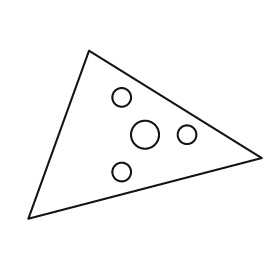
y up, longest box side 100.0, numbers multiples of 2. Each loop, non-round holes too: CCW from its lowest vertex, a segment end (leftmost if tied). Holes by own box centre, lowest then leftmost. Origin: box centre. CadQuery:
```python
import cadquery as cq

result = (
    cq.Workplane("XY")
    .moveTo(-50.0, -36.0)
    .lineTo(50.0, -10.0)
    .lineTo(-24.0, 36.0)
    .close()
    .moveTo(-10.0, -16.0)
    .circle(4.0)
    .moveTo(0.0, 0.0)
    .circle(6.0)
    .moveTo(18.0, 0.0)
    .circle(4.0)
    .moveTo(-10.0, 16.0)
    .circle(4.0)
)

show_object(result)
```